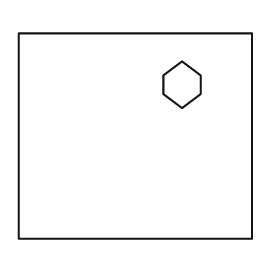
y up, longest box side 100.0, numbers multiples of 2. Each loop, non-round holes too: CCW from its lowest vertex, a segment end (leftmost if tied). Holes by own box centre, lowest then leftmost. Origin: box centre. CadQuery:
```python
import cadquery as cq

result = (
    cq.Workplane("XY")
    .moveTo(-50.0, -44.0)
    .lineTo(50.0, -44.0)
    .lineTo(50.0, 44.0)
    .lineTo(-50.0, 44.0)
    .close()
    .moveTo(20.0, 12.0)
    .lineTo(28.0, 18.0)
    .lineTo(28.0, 26.0)
    .lineTo(20.0, 32.0)
    .lineTo(12.0, 26.0)
    .lineTo(12.0, 18.0)
    .close()
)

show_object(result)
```